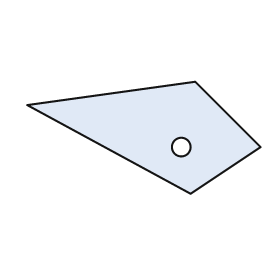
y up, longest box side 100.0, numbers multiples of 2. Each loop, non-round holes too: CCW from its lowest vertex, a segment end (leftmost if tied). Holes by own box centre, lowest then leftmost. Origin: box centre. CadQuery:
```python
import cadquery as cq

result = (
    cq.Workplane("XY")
    .moveTo(20.0, -24.0)
    .lineTo(50.0, -4.0)
    .lineTo(22.0, 24.0)
    .lineTo(-50.0, 14.0)
    .close()
    .moveTo(16.0, -4.0)
    .circle(4.0)
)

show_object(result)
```